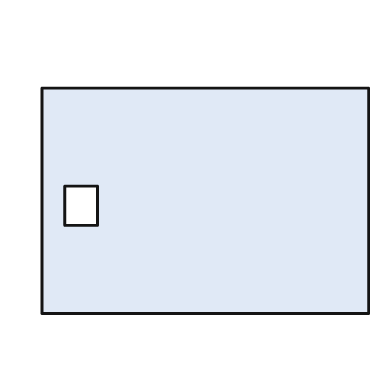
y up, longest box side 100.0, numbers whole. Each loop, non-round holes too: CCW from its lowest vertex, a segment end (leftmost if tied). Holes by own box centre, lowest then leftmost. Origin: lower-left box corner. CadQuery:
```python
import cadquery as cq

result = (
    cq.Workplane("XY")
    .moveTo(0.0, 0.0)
    .lineTo(100.0, 0.0)
    .lineTo(100.0, 69.0)
    .lineTo(0.0, 69.0)
    .close()
    .moveTo(7.0, 27.0)
    .lineTo(17.0, 27.0)
    .lineTo(17.0, 39.0)
    .lineTo(7.0, 39.0)
    .close()
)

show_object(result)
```